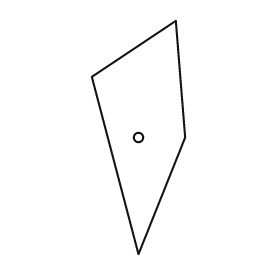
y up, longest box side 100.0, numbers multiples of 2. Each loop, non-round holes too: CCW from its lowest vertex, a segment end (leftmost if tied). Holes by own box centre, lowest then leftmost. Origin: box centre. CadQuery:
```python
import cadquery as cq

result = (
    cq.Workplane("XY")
    .moveTo(0.0, -50.0)
    .lineTo(20.0, 0.0)
    .lineTo(16.0, 50.0)
    .lineTo(-20.0, 26.0)
    .close()
    .moveTo(0.0, 0.0)
    .circle(2.0)
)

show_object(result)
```